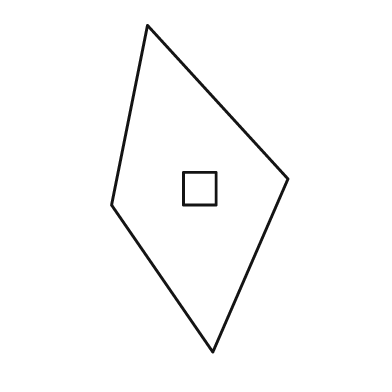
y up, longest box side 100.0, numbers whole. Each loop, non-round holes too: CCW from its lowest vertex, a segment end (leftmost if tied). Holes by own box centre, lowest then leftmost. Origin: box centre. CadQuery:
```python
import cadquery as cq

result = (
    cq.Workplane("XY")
    .moveTo(4.0, -50.0)
    .lineTo(27.0, 3.0)
    .lineTo(-16.0, 50.0)
    .lineTo(-27.0, -5.0)
    .close()
    .moveTo(-5.0, -5.0)
    .lineTo(5.0, -5.0)
    .lineTo(5.0, 5.0)
    .lineTo(-5.0, 5.0)
    .close()
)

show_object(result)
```